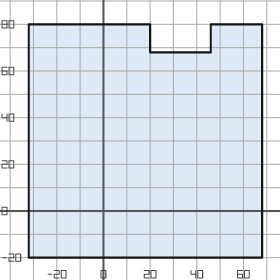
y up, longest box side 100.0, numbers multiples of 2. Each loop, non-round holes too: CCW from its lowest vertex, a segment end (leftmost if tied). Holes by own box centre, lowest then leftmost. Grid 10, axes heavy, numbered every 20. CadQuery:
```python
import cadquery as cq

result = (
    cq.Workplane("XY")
    .moveTo(-32.0, -20.0)
    .lineTo(68.0, -20.0)
    .lineTo(68.0, 80.0)
    .lineTo(46.0, 80.0)
    .lineTo(46.0, 68.0)
    .lineTo(20.0, 68.0)
    .lineTo(20.0, 80.0)
    .lineTo(-32.0, 80.0)
    .close()
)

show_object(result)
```